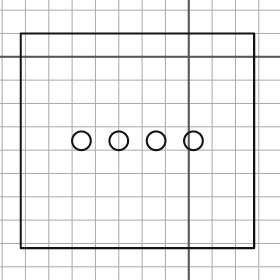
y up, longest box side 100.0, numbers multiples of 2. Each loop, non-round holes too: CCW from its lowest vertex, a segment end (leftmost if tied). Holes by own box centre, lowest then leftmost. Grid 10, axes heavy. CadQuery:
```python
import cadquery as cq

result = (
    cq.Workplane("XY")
    .moveTo(-72.0, -82.0)
    .lineTo(28.0, -82.0)
    .lineTo(28.0, 10.0)
    .lineTo(-72.0, 10.0)
    .close()
    .moveTo(-46.0, -36.0)
    .circle(4.0)
    .moveTo(-30.0, -36.0)
    .circle(4.0)
    .moveTo(-14.0, -36.0)
    .circle(4.0)
    .moveTo(2.0, -36.0)
    .circle(4.0)
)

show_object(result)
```